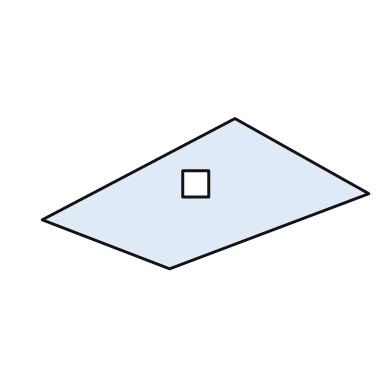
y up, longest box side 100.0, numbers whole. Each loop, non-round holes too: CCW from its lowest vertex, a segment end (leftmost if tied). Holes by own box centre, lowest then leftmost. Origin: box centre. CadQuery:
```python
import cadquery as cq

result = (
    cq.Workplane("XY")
    .moveTo(-11.0, -23.0)
    .lineTo(50.0, 0.0)
    .lineTo(9.0, 23.0)
    .lineTo(-50.0, -8.0)
    .close()
    .moveTo(-7.0, -1.0)
    .lineTo(1.0, -1.0)
    .lineTo(1.0, 7.0)
    .lineTo(-7.0, 7.0)
    .close()
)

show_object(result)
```